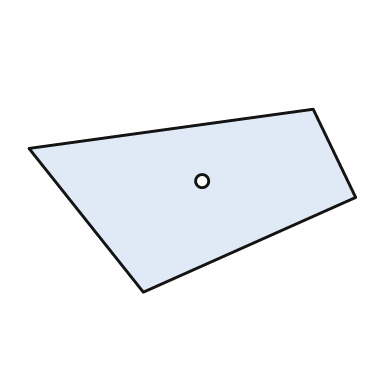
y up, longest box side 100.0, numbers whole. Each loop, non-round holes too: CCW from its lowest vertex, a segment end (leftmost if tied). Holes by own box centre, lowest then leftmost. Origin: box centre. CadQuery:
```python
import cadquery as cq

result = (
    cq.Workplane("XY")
    .moveTo(-15.0, -28.0)
    .lineTo(50.0, 1.0)
    .lineTo(37.0, 28.0)
    .lineTo(-50.0, 16.0)
    .close()
    .moveTo(3.0, 6.0)
    .circle(2.0)
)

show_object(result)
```